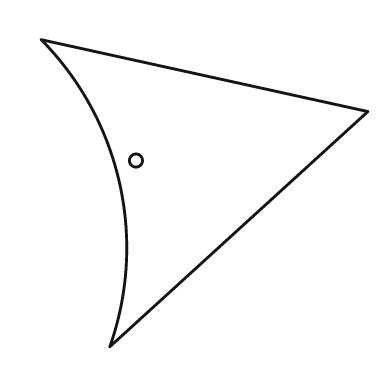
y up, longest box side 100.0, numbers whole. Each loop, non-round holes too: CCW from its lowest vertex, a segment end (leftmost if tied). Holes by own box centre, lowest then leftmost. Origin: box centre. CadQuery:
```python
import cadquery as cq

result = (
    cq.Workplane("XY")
    .moveTo(-29.0, -47.0)
    .lineTo(50.0, 25.0)
    .lineTo(-50.0, 47.0)
    .threePointArc((-26.0, 3.0), (-29.0, -47.0))
    .close()
    .moveTo(-21.0, 10.0)
    .circle(2.0)
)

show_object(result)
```